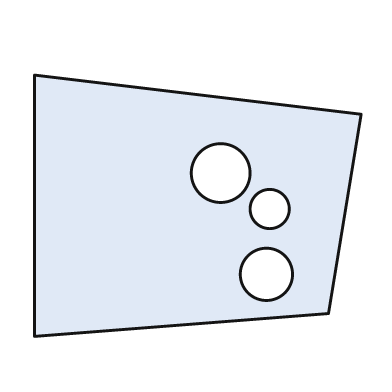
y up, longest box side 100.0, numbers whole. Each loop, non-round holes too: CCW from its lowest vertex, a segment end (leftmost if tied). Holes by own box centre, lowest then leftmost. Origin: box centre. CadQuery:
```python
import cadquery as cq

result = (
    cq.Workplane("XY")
    .moveTo(-50.0, -40.0)
    .lineTo(40.0, -33.0)
    .lineTo(50.0, 28.0)
    .lineTo(-50.0, 40.0)
    .close()
    .moveTo(21.0, -21.0)
    .circle(8.0)
    .moveTo(22.0, -1.0)
    .circle(6.0)
    .moveTo(7.0, 10.0)
    .circle(9.0)
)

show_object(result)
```